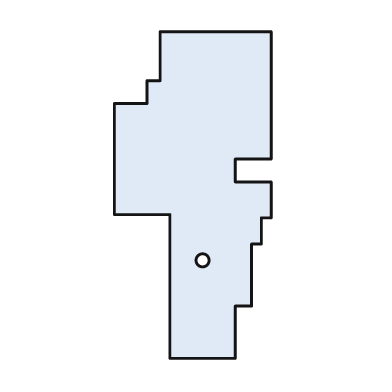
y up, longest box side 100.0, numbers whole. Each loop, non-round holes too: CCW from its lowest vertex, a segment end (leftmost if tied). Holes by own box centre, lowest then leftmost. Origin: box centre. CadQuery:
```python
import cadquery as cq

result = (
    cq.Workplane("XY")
    .moveTo(-7.0, -50.0)
    .lineTo(13.0, -50.0)
    .lineTo(13.0, -34.0)
    .lineTo(18.0, -34.0)
    .lineTo(18.0, -15.0)
    .lineTo(21.0, -15.0)
    .lineTo(21.0, -7.0)
    .lineTo(24.0, -7.0)
    .lineTo(24.0, 4.0)
    .lineTo(13.0, 4.0)
    .lineTo(13.0, 11.0)
    .lineTo(24.0, 11.0)
    .lineTo(24.0, 50.0)
    .lineTo(-10.0, 50.0)
    .lineTo(-10.0, 35.0)
    .lineTo(-14.0, 35.0)
    .lineTo(-14.0, 28.0)
    .lineTo(-24.0, 28.0)
    .lineTo(-24.0, -6.0)
    .lineTo(-7.0, -6.0)
    .close()
    .moveTo(3.0, -20.0)
    .circle(2.0)
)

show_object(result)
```